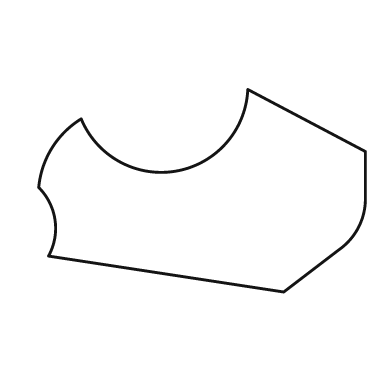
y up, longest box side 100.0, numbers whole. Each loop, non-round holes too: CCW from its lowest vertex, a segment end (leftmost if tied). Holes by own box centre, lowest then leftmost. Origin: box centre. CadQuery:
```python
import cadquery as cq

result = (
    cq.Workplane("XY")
    .moveTo(25.0, -31.0)
    .lineTo(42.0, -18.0)
    .threePointArc((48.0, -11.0), (50.0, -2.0))
    .lineTo(50.0, 12.0)
    .lineTo(14.0, 31.0)
    .threePointArc((-8.0, 6.0), (-37.0, 22.0))
    .threePointArc((-46.0, 13.0), (-50.0, 1.0))
    .threePointArc((-45.0, -9.0), (-47.0, -20.0))
    .close()
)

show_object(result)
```